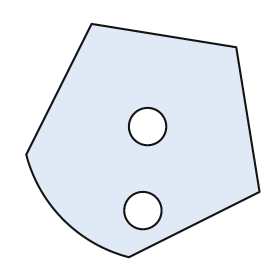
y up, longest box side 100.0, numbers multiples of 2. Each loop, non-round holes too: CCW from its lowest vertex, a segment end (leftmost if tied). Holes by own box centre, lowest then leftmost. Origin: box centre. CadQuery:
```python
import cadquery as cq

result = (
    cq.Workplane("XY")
    .moveTo(-6.0, -50.0)
    .lineTo(50.0, -22.0)
    .lineTo(40.0, 40.0)
    .lineTo(-22.0, 50.0)
    .lineTo(-50.0, -6.0)
    .threePointArc((-34.0, -34.0), (-6.0, -50.0))
    .close()
    .moveTo(0.0, -30.0)
    .circle(8.0)
    .moveTo(2.0, 6.0)
    .circle(8.0)
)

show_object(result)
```